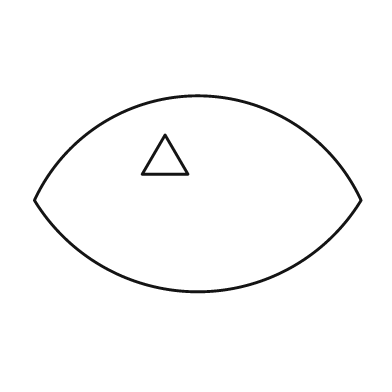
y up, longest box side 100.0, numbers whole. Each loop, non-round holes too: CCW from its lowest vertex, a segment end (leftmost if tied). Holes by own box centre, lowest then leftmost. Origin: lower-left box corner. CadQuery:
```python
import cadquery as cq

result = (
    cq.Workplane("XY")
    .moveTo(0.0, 28.0)
    .threePointArc((50.0, 0.0), (100.0, 28.0))
    .threePointArc((50.0, 60.0), (0.0, 28.0))
    .close()
    .moveTo(33.0, 36.0)
    .lineTo(47.0, 36.0)
    .lineTo(40.0, 48.0)
    .close()
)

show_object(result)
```